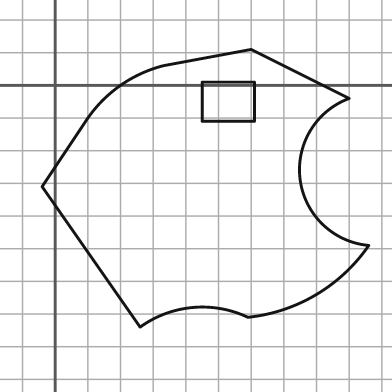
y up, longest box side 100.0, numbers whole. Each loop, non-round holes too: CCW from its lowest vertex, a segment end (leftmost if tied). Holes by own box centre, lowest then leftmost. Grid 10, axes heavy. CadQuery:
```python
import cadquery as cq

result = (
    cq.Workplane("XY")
    .moveTo(26.0, -74.0)
    .threePointArc((42.0, -68.0), (59.0, -71.0))
    .threePointArc((80.0, -64.0), (96.0, -49.0))
    .threePointArc((75.0, -29.0), (90.0, -4.0))
    .lineTo(60.0, 11.0)
    .lineTo(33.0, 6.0)
    .threePointArc((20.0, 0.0), (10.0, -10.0))
    .lineTo(-4.0, -31.0)
    .close()
    .moveTo(45.0, -11.0)
    .lineTo(61.0, -11.0)
    .lineTo(61.0, 1.0)
    .lineTo(45.0, 1.0)
    .close()
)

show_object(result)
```